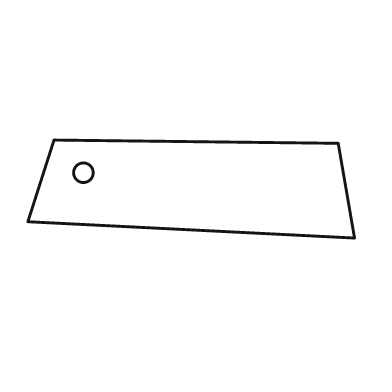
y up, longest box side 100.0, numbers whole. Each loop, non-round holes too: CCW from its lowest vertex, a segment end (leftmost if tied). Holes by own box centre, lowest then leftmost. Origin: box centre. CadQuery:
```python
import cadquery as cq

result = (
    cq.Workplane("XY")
    .moveTo(50.0, -15.0)
    .lineTo(45.0, 14.0)
    .lineTo(-42.0, 15.0)
    .lineTo(-50.0, -10.0)
    .close()
    .moveTo(-33.0, 5.0)
    .circle(3.0)
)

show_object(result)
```